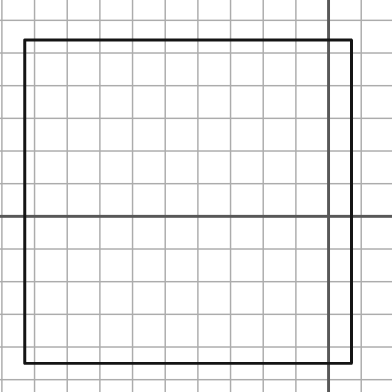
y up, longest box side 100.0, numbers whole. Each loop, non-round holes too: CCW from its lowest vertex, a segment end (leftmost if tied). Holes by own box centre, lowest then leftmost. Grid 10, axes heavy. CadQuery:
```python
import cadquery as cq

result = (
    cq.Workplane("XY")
    .moveTo(-93.0, -45.0)
    .lineTo(7.0, -45.0)
    .lineTo(7.0, 54.0)
    .lineTo(-93.0, 54.0)
    .close()
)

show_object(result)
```